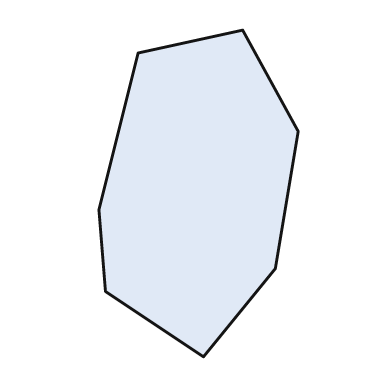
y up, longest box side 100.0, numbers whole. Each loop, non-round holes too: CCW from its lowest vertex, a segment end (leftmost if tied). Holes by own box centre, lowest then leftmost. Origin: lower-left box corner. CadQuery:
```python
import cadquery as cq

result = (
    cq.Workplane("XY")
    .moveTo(32.0, 0.0)
    .lineTo(54.0, 27.0)
    .lineTo(61.0, 69.0)
    .lineTo(44.0, 100.0)
    .lineTo(12.0, 93.0)
    .lineTo(0.0, 45.0)
    .lineTo(2.0, 20.0)
    .close()
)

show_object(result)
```